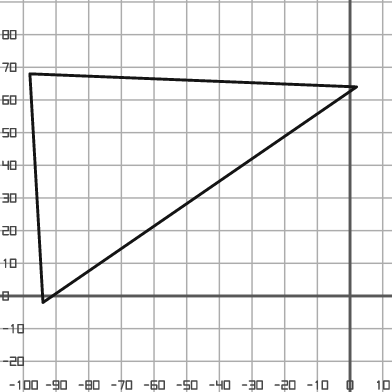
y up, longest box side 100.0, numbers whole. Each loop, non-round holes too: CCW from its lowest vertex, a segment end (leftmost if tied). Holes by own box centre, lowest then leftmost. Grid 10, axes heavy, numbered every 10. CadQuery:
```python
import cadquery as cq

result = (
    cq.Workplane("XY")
    .moveTo(-94.0, -2.0)
    .lineTo(2.0, 64.0)
    .lineTo(-98.0, 68.0)
    .close()
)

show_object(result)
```